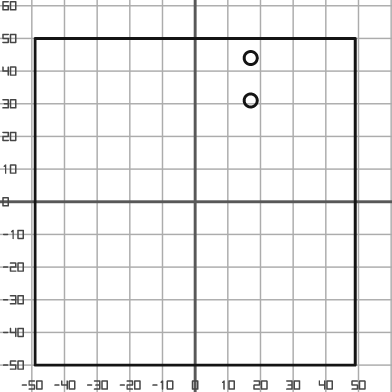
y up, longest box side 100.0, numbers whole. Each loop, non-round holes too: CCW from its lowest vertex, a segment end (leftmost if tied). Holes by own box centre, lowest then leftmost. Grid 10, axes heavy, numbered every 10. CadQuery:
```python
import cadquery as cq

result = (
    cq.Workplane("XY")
    .moveTo(-49.0, -50.0)
    .lineTo(49.0, -50.0)
    .lineTo(49.0, 50.0)
    .lineTo(-49.0, 50.0)
    .close()
    .moveTo(17.0, 31.0)
    .circle(2.0)
    .moveTo(17.0, 44.0)
    .circle(2.0)
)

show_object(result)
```